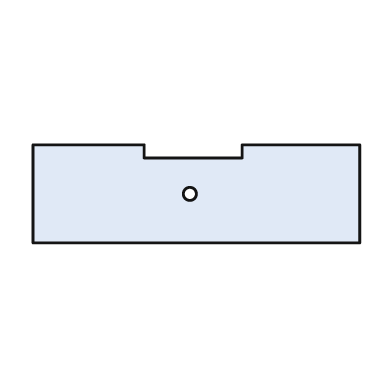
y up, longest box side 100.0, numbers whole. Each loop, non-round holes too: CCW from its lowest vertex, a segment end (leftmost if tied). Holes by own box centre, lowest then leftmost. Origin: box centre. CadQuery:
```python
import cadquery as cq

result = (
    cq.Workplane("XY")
    .moveTo(-50.0, -15.0)
    .lineTo(50.0, -15.0)
    .lineTo(50.0, 15.0)
    .lineTo(14.0, 15.0)
    .lineTo(14.0, 11.0)
    .lineTo(-16.0, 11.0)
    .lineTo(-16.0, 15.0)
    .lineTo(-50.0, 15.0)
    .close()
    .moveTo(-2.0, 0.0)
    .circle(2.0)
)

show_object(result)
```